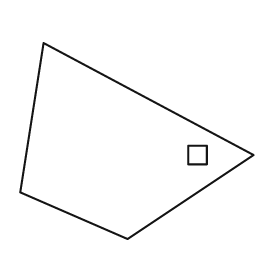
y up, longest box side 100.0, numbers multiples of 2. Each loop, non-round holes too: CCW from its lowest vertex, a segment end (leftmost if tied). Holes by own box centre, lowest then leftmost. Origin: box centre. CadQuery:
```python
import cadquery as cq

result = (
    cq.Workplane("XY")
    .moveTo(-4.0, -42.0)
    .lineTo(50.0, -6.0)
    .lineTo(-40.0, 42.0)
    .lineTo(-50.0, -22.0)
    .close()
    .moveTo(22.0, -10.0)
    .lineTo(30.0, -10.0)
    .lineTo(30.0, -2.0)
    .lineTo(22.0, -2.0)
    .close()
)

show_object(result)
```